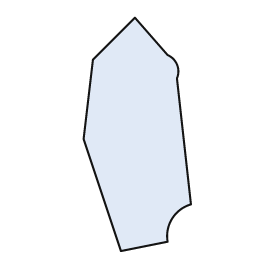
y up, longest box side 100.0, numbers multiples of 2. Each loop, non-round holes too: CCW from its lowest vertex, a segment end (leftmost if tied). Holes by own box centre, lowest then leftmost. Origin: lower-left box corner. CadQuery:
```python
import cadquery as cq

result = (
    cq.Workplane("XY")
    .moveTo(16.0, 0.0)
    .lineTo(36.0, 4.0)
    .threePointArc((38.0, 14.0), (46.0, 20.0))
    .lineTo(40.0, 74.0)
    .threePointArc((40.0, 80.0), (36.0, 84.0))
    .lineTo(22.0, 100.0)
    .lineTo(4.0, 82.0)
    .lineTo(0.0, 48.0)
    .close()
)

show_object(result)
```